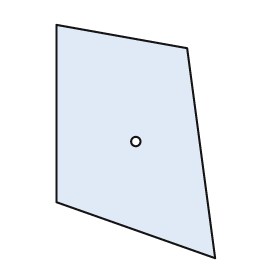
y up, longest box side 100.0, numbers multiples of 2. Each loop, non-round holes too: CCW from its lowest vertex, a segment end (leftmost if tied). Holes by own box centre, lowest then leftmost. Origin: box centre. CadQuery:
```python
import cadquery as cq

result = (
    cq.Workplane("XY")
    .moveTo(34.0, -50.0)
    .lineTo(22.0, 40.0)
    .lineTo(-34.0, 50.0)
    .lineTo(-34.0, -26.0)
    .close()
    .moveTo(0.0, 0.0)
    .circle(2.0)
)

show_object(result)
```